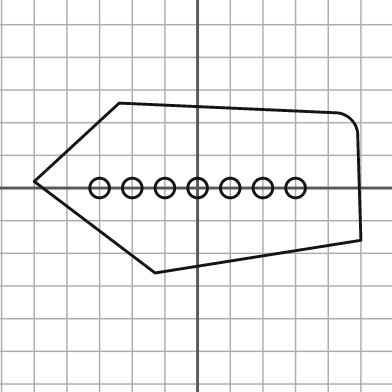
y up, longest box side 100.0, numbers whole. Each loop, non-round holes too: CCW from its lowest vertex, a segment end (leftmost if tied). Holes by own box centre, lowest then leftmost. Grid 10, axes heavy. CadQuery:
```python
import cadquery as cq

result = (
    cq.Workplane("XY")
    .moveTo(-13.0, -26.0)
    .lineTo(50.0, -16.0)
    .lineTo(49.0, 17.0)
    .threePointArc((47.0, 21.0), (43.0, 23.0))
    .lineTo(-24.0, 26.0)
    .lineTo(-50.0, 2.0)
    .close()
    .moveTo(-30.0, 0.0)
    .circle(3.0)
    .moveTo(-20.0, 0.0)
    .circle(3.0)
    .moveTo(-10.0, 0.0)
    .circle(3.0)
    .moveTo(0.0, 0.0)
    .circle(3.0)
    .moveTo(10.0, 0.0)
    .circle(3.0)
    .moveTo(20.0, 0.0)
    .circle(3.0)
    .moveTo(30.0, 0.0)
    .circle(3.0)
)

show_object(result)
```